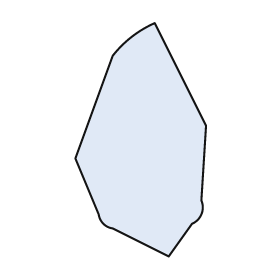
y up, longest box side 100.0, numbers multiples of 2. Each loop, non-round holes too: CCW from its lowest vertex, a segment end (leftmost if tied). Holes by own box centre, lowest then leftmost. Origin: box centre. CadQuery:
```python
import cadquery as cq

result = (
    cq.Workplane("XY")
    .moveTo(12.0, -50.0)
    .lineTo(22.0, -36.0)
    .threePointArc((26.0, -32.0), (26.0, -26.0))
    .lineTo(28.0, 6.0)
    .lineTo(6.0, 50.0)
    .threePointArc((-4.0, 44.0), (-12.0, 36.0))
    .lineTo(-28.0, -8.0)
    .lineTo(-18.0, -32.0)
    .threePointArc((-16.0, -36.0), (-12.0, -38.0))
    .close()
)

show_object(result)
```